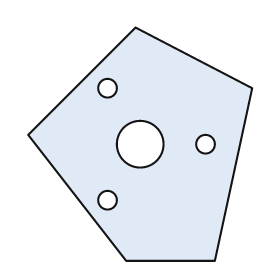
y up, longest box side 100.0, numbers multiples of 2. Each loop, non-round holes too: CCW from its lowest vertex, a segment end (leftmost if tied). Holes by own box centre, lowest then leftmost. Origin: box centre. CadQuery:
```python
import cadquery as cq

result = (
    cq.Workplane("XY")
    .moveTo(-6.0, -50.0)
    .lineTo(32.0, -50.0)
    .lineTo(48.0, 24.0)
    .lineTo(-2.0, 50.0)
    .lineTo(-48.0, 4.0)
    .close()
    .moveTo(-14.0, -24.0)
    .circle(4.0)
    .moveTo(0.0, 0.0)
    .circle(10.0)
    .moveTo(28.0, 0.0)
    .circle(4.0)
    .moveTo(-14.0, 24.0)
    .circle(4.0)
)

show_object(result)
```